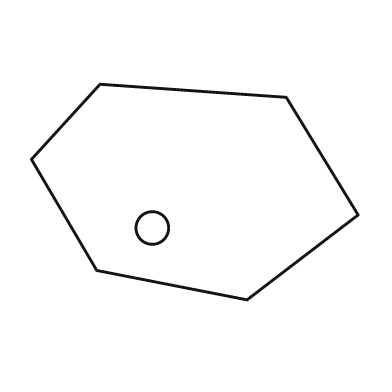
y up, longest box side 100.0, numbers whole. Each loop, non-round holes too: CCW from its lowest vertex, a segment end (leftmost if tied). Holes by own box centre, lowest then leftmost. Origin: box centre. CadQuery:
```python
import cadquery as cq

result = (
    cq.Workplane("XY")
    .moveTo(16.0, -33.0)
    .lineTo(50.0, -7.0)
    .lineTo(28.0, 29.0)
    .lineTo(-29.0, 33.0)
    .lineTo(-50.0, 10.0)
    .lineTo(-30.0, -24.0)
    .close()
    .moveTo(-13.0, -11.0)
    .circle(5.0)
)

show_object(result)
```